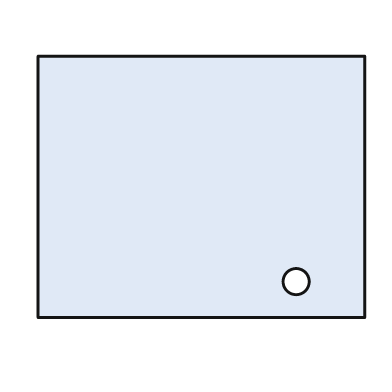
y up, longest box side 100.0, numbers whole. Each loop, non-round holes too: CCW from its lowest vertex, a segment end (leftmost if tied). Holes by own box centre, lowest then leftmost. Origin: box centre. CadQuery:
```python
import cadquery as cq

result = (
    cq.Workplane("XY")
    .moveTo(-50.0, -40.0)
    .lineTo(50.0, -40.0)
    .lineTo(50.0, 40.0)
    .lineTo(-50.0, 40.0)
    .close()
    .moveTo(29.0, -29.0)
    .circle(4.0)
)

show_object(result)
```